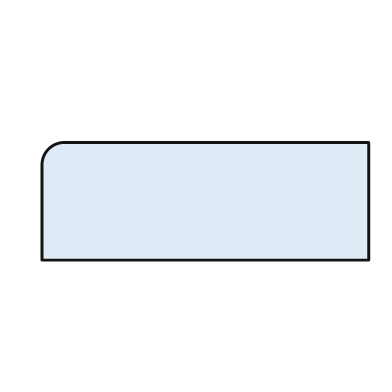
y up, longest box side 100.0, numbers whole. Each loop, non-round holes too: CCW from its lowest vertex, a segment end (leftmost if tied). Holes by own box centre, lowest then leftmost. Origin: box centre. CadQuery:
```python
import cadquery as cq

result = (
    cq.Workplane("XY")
    .moveTo(-50.0, -18.0)
    .lineTo(50.0, -18.0)
    .lineTo(50.0, 18.0)
    .lineTo(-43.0, 18.0)
    .threePointArc((-48.0, 16.0), (-50.0, 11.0))
    .close()
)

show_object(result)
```